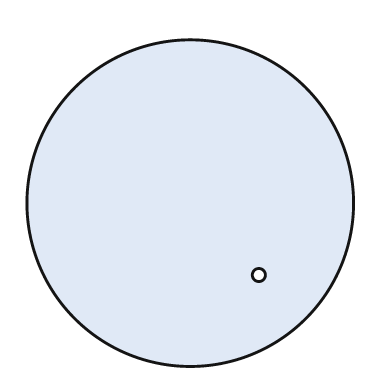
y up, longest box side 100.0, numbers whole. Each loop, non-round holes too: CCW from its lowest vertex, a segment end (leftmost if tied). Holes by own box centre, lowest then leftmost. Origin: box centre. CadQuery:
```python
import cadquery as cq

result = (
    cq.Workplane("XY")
    .moveTo(0.0, 0.0)
    .circle(50.0)
    .moveTo(21.0, -22.0)
    .circle(2.0)
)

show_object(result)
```